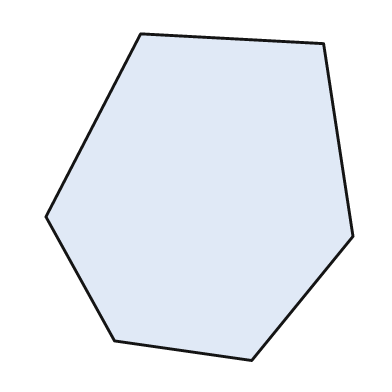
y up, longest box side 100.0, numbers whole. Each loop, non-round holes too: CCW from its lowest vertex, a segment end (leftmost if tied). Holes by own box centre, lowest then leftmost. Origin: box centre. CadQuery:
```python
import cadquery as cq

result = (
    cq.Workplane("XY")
    .moveTo(16.0, -50.0)
    .lineTo(47.0, -12.0)
    .lineTo(38.0, 47.0)
    .lineTo(-18.0, 50.0)
    .lineTo(-47.0, -6.0)
    .lineTo(-26.0, -44.0)
    .close()
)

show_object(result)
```